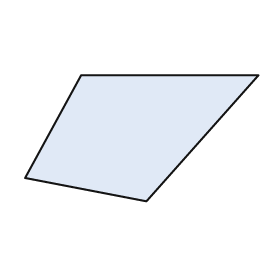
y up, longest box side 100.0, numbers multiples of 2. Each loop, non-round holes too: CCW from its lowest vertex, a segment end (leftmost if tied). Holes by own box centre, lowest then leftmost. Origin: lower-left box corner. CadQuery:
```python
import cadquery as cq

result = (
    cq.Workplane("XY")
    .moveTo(52.0, 0.0)
    .lineTo(100.0, 54.0)
    .lineTo(24.0, 54.0)
    .lineTo(0.0, 10.0)
    .close()
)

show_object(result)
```